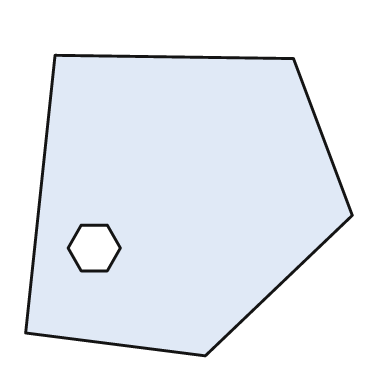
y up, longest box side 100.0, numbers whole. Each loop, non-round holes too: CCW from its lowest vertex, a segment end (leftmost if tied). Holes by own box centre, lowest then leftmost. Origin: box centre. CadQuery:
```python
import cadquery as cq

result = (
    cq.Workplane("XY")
    .moveTo(5.0, -46.0)
    .lineTo(50.0, -3.0)
    .lineTo(32.0, 45.0)
    .lineTo(-41.0, 46.0)
    .lineTo(-50.0, -39.0)
    .close()
    .moveTo(-33.0, -20.0)
    .lineTo(-25.0, -20.0)
    .lineTo(-21.0, -13.0)
    .lineTo(-25.0, -6.0)
    .lineTo(-33.0, -6.0)
    .lineTo(-37.0, -13.0)
    .close()
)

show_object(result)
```